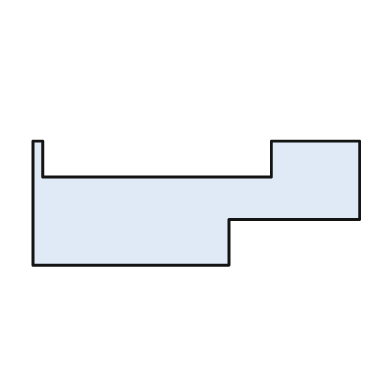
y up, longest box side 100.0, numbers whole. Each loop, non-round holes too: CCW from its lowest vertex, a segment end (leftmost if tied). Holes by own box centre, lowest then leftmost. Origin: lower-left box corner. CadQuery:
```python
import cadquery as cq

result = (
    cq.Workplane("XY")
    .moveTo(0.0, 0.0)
    .lineTo(60.0, 0.0)
    .lineTo(60.0, 14.0)
    .lineTo(100.0, 14.0)
    .lineTo(100.0, 38.0)
    .lineTo(73.0, 38.0)
    .lineTo(73.0, 27.0)
    .lineTo(3.0, 27.0)
    .lineTo(3.0, 38.0)
    .lineTo(0.0, 38.0)
    .close()
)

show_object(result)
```